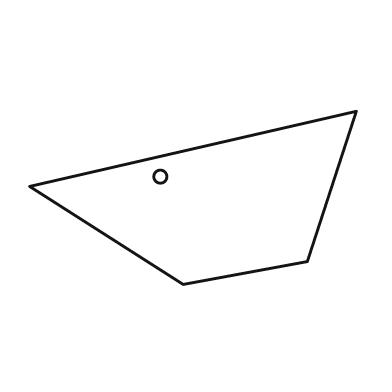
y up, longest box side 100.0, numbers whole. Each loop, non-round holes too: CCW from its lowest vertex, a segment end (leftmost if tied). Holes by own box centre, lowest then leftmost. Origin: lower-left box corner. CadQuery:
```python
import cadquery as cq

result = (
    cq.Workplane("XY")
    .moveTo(47.0, 0.0)
    .lineTo(85.0, 7.0)
    .lineTo(100.0, 53.0)
    .lineTo(0.0, 30.0)
    .close()
    .moveTo(40.0, 33.0)
    .circle(2.0)
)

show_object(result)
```